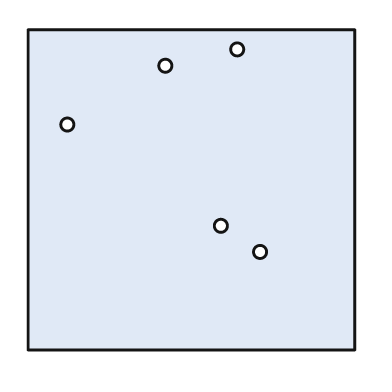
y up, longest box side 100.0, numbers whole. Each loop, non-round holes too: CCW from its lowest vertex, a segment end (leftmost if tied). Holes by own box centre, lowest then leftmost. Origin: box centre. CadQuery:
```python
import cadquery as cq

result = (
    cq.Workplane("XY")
    .moveTo(-50.0, -49.0)
    .lineTo(50.0, -49.0)
    .lineTo(50.0, 49.0)
    .lineTo(-50.0, 49.0)
    .close()
    .moveTo(21.0, -19.0)
    .circle(2.0)
    .moveTo(9.0, -11.0)
    .circle(2.0)
    .moveTo(-38.0, 20.0)
    .circle(2.0)
    .moveTo(-8.0, 38.0)
    .circle(2.0)
    .moveTo(14.0, 43.0)
    .circle(2.0)
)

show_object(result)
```